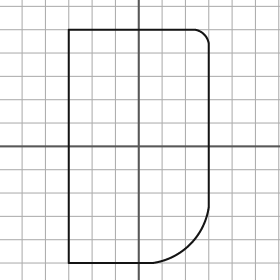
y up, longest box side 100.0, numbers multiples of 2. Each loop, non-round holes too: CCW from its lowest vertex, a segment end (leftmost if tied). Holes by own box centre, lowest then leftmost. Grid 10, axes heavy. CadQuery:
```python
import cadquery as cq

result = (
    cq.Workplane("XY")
    .moveTo(-30.0, -50.0)
    .lineTo(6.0, -50.0)
    .threePointArc((22.0, -42.0), (30.0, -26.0))
    .lineTo(30.0, 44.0)
    .threePointArc((28.0, 48.0), (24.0, 50.0))
    .lineTo(-30.0, 50.0)
    .close()
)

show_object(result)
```